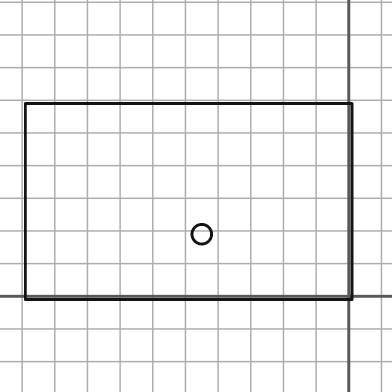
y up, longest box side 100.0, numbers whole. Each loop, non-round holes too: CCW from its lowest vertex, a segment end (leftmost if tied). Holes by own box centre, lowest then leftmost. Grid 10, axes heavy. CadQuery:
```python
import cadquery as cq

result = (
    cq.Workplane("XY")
    .moveTo(-99.0, -1.0)
    .lineTo(1.0, -1.0)
    .lineTo(1.0, 59.0)
    .lineTo(-99.0, 59.0)
    .close()
    .moveTo(-45.0, 19.0)
    .circle(3.0)
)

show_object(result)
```